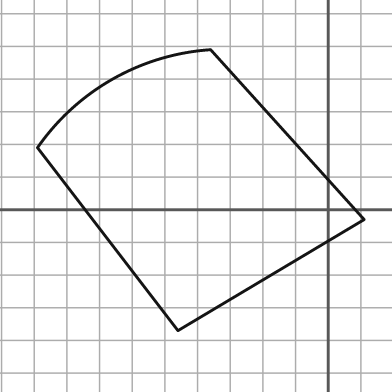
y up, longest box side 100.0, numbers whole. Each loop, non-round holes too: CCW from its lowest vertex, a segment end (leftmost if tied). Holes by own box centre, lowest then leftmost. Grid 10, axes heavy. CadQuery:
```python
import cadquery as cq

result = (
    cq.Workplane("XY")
    .moveTo(-46.0, -37.0)
    .lineTo(11.0, -3.0)
    .lineTo(-36.0, 49.0)
    .threePointArc((-66.0, 40.0), (-89.0, 19.0))
    .close()
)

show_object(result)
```